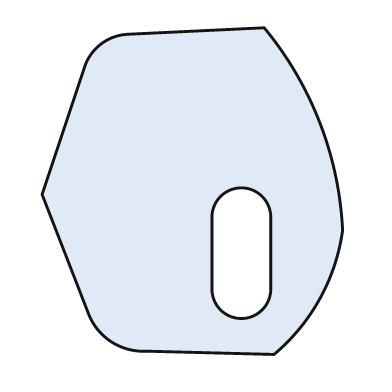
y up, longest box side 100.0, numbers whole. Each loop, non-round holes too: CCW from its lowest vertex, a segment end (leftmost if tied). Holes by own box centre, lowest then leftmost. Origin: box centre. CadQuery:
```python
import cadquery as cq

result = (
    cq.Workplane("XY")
    .moveTo(25.0, -50.0)
    .threePointArc((39.0, -33.0), (46.0, -12.0))
    .threePointArc((39.0, 21.0), (22.0, 50.0))
    .lineTo(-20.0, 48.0)
    .threePointArc((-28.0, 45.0), (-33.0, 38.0))
    .lineTo(-46.0, -1.0)
    .lineTo(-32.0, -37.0)
    .threePointArc((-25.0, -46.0), (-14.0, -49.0))
    .close()
    .moveTo(6.0, -30.0)
    .threePointArc((15.0, -39.0), (24.0, -30.0))
    .lineTo(24.0, -8.0)
    .threePointArc((15.0, 1.0), (6.0, -8.0))
    .close()
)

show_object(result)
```